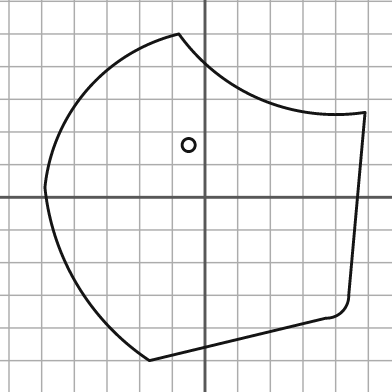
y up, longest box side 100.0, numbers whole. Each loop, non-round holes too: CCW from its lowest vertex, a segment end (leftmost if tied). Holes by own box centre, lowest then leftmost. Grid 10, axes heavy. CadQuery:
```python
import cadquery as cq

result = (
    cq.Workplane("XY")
    .moveTo(-17.0, -50.0)
    .lineTo(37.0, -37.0)
    .threePointArc((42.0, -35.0), (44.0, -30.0))
    .lineTo(49.0, 26.0)
    .threePointArc((17.0, 30.0), (-8.0, 50.0))
    .threePointArc((-36.0, 33.0), (-49.0, 3.0))
    .threePointArc((-39.0, -27.0), (-17.0, -50.0))
    .close()
    .moveTo(-5.0, 16.0)
    .circle(2.0)
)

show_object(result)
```